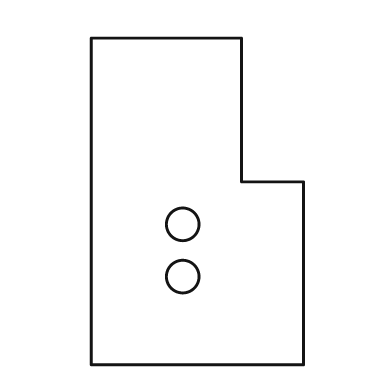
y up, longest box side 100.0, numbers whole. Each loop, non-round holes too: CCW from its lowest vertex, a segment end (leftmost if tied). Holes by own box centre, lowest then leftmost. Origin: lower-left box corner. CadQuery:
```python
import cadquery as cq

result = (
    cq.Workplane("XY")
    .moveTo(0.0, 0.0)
    .lineTo(65.0, 0.0)
    .lineTo(65.0, 56.0)
    .lineTo(46.0, 56.0)
    .lineTo(46.0, 100.0)
    .lineTo(0.0, 100.0)
    .close()
    .moveTo(28.0, 27.0)
    .circle(5.0)
    .moveTo(28.0, 43.0)
    .circle(5.0)
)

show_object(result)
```